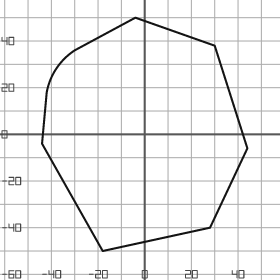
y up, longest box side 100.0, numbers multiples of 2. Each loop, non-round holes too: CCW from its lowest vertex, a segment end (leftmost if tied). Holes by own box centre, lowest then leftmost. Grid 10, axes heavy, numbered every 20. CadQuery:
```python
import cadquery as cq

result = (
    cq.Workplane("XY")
    .moveTo(-18.0, -50.0)
    .lineTo(28.0, -40.0)
    .lineTo(44.0, -6.0)
    .lineTo(30.0, 38.0)
    .lineTo(-4.0, 50.0)
    .lineTo(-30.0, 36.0)
    .threePointArc((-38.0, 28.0), (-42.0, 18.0))
    .lineTo(-44.0, -4.0)
    .close()
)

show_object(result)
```